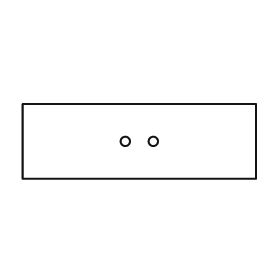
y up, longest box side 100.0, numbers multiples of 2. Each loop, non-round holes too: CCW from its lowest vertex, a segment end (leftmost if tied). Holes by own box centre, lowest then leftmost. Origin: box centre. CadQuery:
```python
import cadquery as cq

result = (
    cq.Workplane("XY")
    .moveTo(-50.0, -16.0)
    .lineTo(50.0, -16.0)
    .lineTo(50.0, 16.0)
    .lineTo(-50.0, 16.0)
    .close()
    .moveTo(-6.0, 0.0)
    .circle(2.0)
    .moveTo(6.0, 0.0)
    .circle(2.0)
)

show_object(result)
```